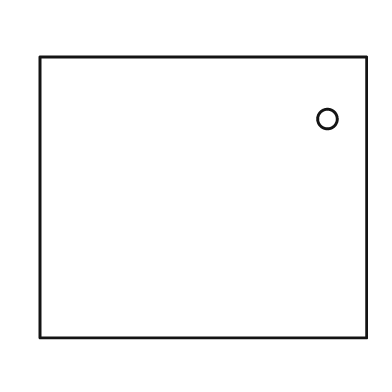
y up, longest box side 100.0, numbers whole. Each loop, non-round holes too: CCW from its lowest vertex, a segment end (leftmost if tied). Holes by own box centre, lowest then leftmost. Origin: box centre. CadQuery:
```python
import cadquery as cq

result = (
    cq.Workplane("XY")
    .moveTo(-50.0, -43.0)
    .lineTo(50.0, -43.0)
    .lineTo(50.0, 43.0)
    .lineTo(-50.0, 43.0)
    .close()
    .moveTo(38.0, 24.0)
    .circle(3.0)
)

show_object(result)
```